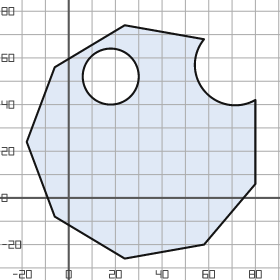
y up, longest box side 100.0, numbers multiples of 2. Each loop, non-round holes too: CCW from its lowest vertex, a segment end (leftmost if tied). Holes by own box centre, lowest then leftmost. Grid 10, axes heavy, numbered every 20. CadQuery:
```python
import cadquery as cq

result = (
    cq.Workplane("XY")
    .moveTo(24.0, -26.0)
    .lineTo(58.0, -20.0)
    .lineTo(80.0, 6.0)
    .lineTo(80.0, 42.0)
    .threePointArc((58.0, 46.0), (58.0, 68.0))
    .lineTo(24.0, 74.0)
    .lineTo(-6.0, 56.0)
    .lineTo(-18.0, 24.0)
    .lineTo(-6.0, -8.0)
    .close()
    .moveTo(18.0, 52.0)
    .circle(12.0)
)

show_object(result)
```